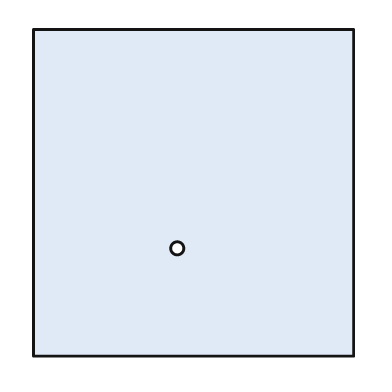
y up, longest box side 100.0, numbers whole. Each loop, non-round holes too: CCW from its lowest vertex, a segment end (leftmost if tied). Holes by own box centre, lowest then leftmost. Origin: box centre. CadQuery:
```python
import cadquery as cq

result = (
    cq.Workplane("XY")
    .moveTo(-49.0, -50.0)
    .lineTo(49.0, -50.0)
    .lineTo(49.0, 50.0)
    .lineTo(-49.0, 50.0)
    .close()
    .moveTo(-5.0, -17.0)
    .circle(2.0)
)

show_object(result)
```